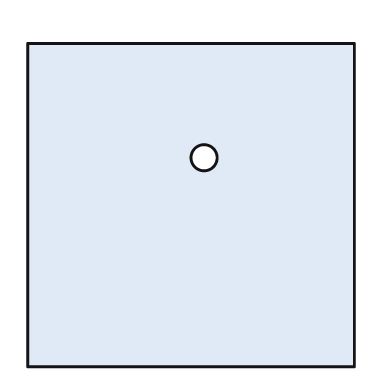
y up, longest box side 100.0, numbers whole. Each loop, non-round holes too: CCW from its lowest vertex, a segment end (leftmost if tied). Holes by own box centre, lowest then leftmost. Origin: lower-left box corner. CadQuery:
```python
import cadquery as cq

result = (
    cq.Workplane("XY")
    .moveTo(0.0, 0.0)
    .lineTo(100.0, 0.0)
    .lineTo(100.0, 99.0)
    .lineTo(0.0, 99.0)
    .close()
    .moveTo(54.0, 64.0)
    .circle(4.0)
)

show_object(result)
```